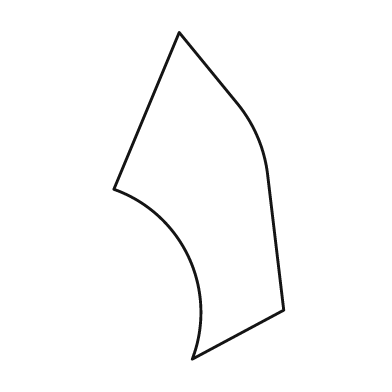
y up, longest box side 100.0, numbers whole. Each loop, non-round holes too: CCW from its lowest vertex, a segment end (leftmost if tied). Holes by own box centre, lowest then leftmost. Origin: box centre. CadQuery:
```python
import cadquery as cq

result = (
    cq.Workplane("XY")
    .moveTo(-2.0, -50.0)
    .lineTo(26.0, -35.0)
    .lineTo(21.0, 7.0)
    .threePointArc((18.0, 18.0), (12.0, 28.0))
    .lineTo(-6.0, 50.0)
    .lineTo(-26.0, 2.0)
    .threePointArc((-3.0, -19.0), (-2.0, -50.0))
    .close()
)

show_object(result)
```